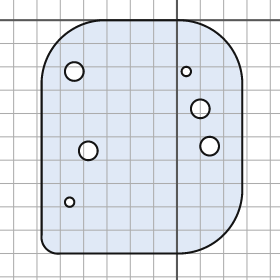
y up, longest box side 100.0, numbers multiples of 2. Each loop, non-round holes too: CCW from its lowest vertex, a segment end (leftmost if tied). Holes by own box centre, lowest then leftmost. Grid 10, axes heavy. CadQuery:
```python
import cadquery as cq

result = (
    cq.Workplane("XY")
    .moveTo(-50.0, -100.0)
    .lineTo(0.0, -100.0)
    .threePointArc((20.0, -92.0), (28.0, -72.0))
    .lineTo(28.0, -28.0)
    .threePointArc((20.0, -8.0), (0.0, 0.0))
    .lineTo(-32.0, 0.0)
    .threePointArc((-50.0, -8.0), (-58.0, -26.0))
    .lineTo(-58.0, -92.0)
    .threePointArc((-56.0, -98.0), (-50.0, -100.0))
    .close()
    .moveTo(-46.0, -78.0)
    .circle(2.0)
    .moveTo(-38.0, -56.0)
    .circle(4.0)
    .moveTo(14.0, -54.0)
    .circle(4.0)
    .moveTo(10.0, -38.0)
    .circle(4.0)
    .moveTo(-44.0, -22.0)
    .circle(4.0)
    .moveTo(4.0, -22.0)
    .circle(2.0)
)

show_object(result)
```